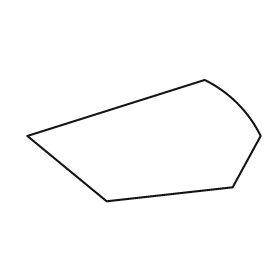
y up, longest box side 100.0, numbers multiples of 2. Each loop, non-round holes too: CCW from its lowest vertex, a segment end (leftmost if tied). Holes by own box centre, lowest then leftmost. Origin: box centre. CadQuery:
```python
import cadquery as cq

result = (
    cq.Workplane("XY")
    .moveTo(-16.0, -26.0)
    .lineTo(38.0, -20.0)
    .lineTo(50.0, 2.0)
    .threePointArc((40.0, 16.0), (26.0, 26.0))
    .lineTo(-50.0, 2.0)
    .close()
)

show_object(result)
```